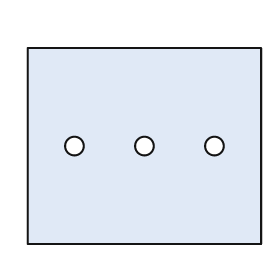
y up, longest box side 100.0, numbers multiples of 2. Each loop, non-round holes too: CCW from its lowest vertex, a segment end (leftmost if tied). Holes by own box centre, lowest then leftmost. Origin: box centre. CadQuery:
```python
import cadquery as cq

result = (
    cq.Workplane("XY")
    .moveTo(-50.0, -42.0)
    .lineTo(50.0, -42.0)
    .lineTo(50.0, 42.0)
    .lineTo(-50.0, 42.0)
    .close()
    .moveTo(-30.0, 0.0)
    .circle(4.0)
    .moveTo(0.0, 0.0)
    .circle(4.0)
    .moveTo(30.0, 0.0)
    .circle(4.0)
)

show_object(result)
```